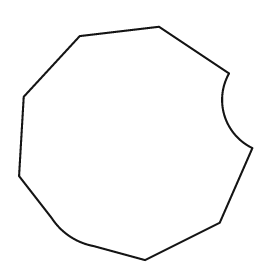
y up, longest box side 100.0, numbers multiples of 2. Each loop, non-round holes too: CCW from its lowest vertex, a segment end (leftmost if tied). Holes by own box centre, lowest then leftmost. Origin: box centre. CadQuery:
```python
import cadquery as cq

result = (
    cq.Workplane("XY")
    .moveTo(4.0, -50.0)
    .lineTo(36.0, -34.0)
    .lineTo(50.0, -2.0)
    .threePointArc((38.0, 12.0), (40.0, 30.0))
    .lineTo(10.0, 50.0)
    .lineTo(-24.0, 46.0)
    .lineTo(-48.0, 20.0)
    .lineTo(-50.0, -14.0)
    .lineTo(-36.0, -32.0)
    .threePointArc((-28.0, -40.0), (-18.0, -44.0))
    .close()
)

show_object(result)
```